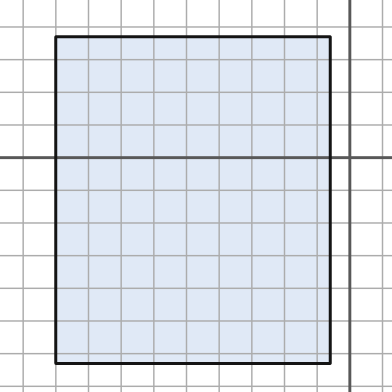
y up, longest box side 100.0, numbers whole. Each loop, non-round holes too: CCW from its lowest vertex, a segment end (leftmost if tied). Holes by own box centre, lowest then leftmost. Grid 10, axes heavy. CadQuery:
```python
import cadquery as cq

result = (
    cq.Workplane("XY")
    .moveTo(-90.0, -63.0)
    .lineTo(-6.0, -63.0)
    .lineTo(-6.0, 37.0)
    .lineTo(-90.0, 37.0)
    .close()
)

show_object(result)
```